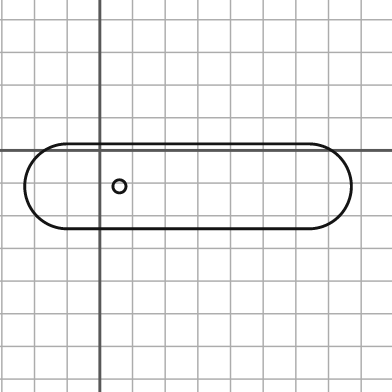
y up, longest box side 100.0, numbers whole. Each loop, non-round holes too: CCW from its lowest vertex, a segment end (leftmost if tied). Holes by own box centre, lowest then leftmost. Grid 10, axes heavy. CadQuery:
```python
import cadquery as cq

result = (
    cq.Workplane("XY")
    .moveTo(-10.0, -24.0)
    .lineTo(64.0, -24.0)
    .threePointArc((77.0, -11.0), (64.0, 2.0))
    .lineTo(-10.0, 2.0)
    .threePointArc((-23.0, -11.0), (-10.0, -24.0))
    .close()
    .moveTo(6.0, -11.0)
    .circle(2.0)
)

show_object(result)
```